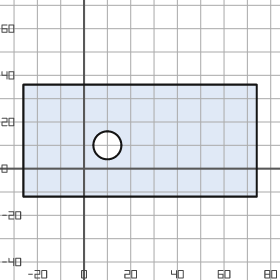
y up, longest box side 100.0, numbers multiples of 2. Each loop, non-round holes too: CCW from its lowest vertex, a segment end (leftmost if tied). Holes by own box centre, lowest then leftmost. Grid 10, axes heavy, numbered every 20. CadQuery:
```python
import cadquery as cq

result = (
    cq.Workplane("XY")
    .moveTo(-26.0, -12.0)
    .lineTo(74.0, -12.0)
    .lineTo(74.0, 36.0)
    .lineTo(-26.0, 36.0)
    .close()
    .moveTo(10.0, 10.0)
    .circle(6.0)
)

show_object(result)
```